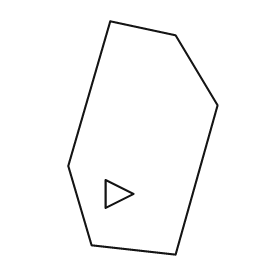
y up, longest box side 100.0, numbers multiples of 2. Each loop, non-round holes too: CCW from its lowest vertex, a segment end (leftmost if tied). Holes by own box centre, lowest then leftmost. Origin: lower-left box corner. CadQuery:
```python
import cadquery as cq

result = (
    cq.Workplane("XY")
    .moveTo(46.0, 0.0)
    .lineTo(64.0, 64.0)
    .lineTo(46.0, 94.0)
    .lineTo(18.0, 100.0)
    .lineTo(0.0, 38.0)
    .lineTo(10.0, 4.0)
    .close()
    .moveTo(16.0, 20.0)
    .lineTo(28.0, 26.0)
    .lineTo(16.0, 32.0)
    .close()
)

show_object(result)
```